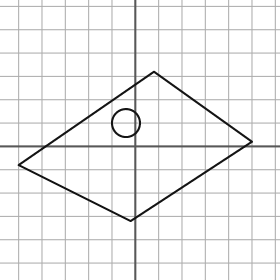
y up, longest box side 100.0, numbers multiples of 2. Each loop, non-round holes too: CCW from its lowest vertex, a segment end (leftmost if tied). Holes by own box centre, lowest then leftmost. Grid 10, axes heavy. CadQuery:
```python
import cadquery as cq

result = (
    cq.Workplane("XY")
    .moveTo(-2.0, -32.0)
    .lineTo(50.0, 2.0)
    .lineTo(8.0, 32.0)
    .lineTo(-50.0, -8.0)
    .close()
    .moveTo(-4.0, 10.0)
    .circle(6.0)
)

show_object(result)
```